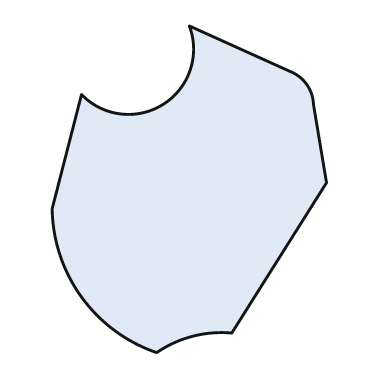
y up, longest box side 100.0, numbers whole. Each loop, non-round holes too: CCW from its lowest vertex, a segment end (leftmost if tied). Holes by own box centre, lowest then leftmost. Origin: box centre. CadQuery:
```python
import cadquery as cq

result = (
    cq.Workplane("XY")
    .moveTo(-10.0, -50.0)
    .threePointArc((1.0, -45.0), (13.0, -44.0))
    .lineTo(42.0, 2.0)
    .lineTo(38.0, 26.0)
    .threePointArc((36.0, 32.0), (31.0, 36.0))
    .lineTo(0.0, 50.0)
    .threePointArc((-8.0, 26.0), (-33.0, 29.0))
    .lineTo(-42.0, -6.0)
    .threePointArc((-33.0, -33.0), (-10.0, -50.0))
    .close()
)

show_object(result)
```